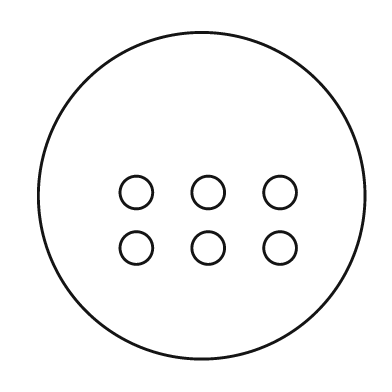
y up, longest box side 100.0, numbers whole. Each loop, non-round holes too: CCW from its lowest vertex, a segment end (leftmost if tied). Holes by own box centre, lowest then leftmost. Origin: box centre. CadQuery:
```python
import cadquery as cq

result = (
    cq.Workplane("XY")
    .moveTo(0.0, 0.0)
    .circle(50.0)
    .moveTo(-20.0, -16.0)
    .circle(5.0)
    .moveTo(2.0, -16.0)
    .circle(5.0)
    .moveTo(24.0, -16.0)
    .circle(5.0)
    .moveTo(-20.0, 1.0)
    .circle(5.0)
    .moveTo(2.0, 1.0)
    .circle(5.0)
    .moveTo(24.0, 1.0)
    .circle(5.0)
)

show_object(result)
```